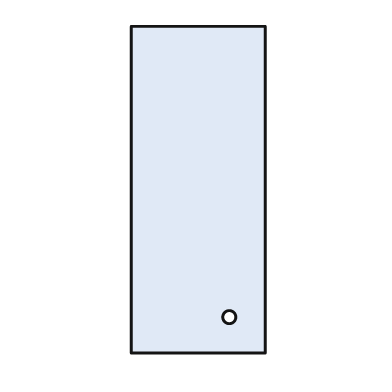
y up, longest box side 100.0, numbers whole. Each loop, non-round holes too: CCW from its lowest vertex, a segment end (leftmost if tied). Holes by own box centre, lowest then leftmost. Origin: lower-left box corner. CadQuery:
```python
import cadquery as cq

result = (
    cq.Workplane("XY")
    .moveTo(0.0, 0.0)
    .lineTo(41.0, 0.0)
    .lineTo(41.0, 100.0)
    .lineTo(0.0, 100.0)
    .close()
    .moveTo(30.0, 11.0)
    .circle(2.0)
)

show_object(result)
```